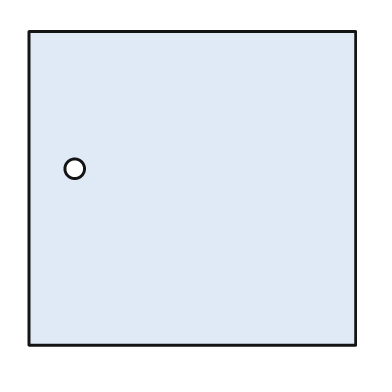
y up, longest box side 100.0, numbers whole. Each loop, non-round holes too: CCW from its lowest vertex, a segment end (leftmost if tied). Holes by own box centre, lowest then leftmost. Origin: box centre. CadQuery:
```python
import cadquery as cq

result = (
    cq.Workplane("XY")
    .moveTo(-50.0, -48.0)
    .lineTo(50.0, -48.0)
    .lineTo(50.0, 48.0)
    .lineTo(-50.0, 48.0)
    .close()
    .moveTo(-36.0, 6.0)
    .circle(3.0)
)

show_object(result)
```